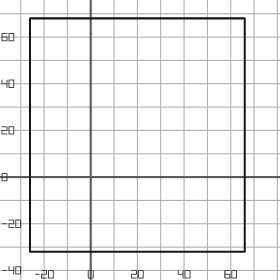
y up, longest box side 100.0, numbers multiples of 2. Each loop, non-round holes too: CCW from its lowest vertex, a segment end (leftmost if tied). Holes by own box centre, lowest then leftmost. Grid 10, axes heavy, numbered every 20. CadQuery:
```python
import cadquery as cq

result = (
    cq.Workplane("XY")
    .moveTo(-26.0, -32.0)
    .lineTo(66.0, -32.0)
    .lineTo(66.0, 68.0)
    .lineTo(-26.0, 68.0)
    .close()
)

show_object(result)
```